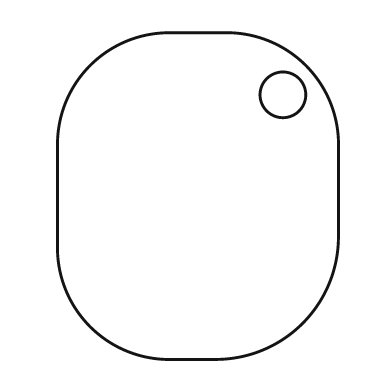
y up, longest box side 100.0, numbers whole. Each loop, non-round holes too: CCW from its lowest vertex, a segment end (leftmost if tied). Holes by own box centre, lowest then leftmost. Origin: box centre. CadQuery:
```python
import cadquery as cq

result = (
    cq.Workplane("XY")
    .moveTo(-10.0, -50.0)
    .lineTo(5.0, -50.0)
    .threePointArc((32.0, -39.0), (43.0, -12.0))
    .lineTo(43.0, 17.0)
    .threePointArc((33.0, 40.0), (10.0, 50.0))
    .lineTo(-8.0, 50.0)
    .threePointArc((-33.0, 40.0), (-43.0, 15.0))
    .lineTo(-43.0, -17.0)
    .threePointArc((-33.0, -40.0), (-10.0, -50.0))
    .close()
    .moveTo(26.0, 31.0)
    .circle(7.0)
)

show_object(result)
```